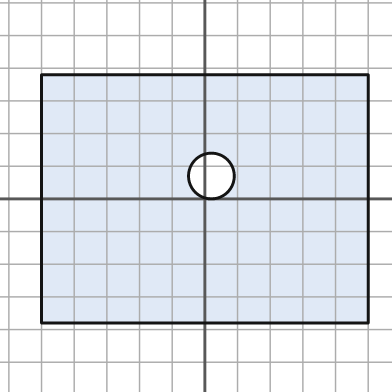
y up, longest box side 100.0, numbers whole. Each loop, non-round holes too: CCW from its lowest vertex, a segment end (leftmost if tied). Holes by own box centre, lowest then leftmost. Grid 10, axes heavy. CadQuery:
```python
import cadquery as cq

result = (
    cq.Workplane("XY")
    .moveTo(-50.0, -38.0)
    .lineTo(50.0, -38.0)
    .lineTo(50.0, 38.0)
    .lineTo(-50.0, 38.0)
    .close()
    .moveTo(2.0, 7.0)
    .circle(7.0)
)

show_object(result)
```